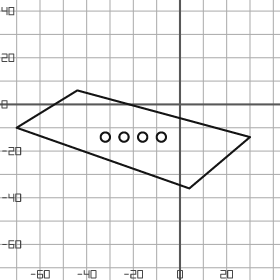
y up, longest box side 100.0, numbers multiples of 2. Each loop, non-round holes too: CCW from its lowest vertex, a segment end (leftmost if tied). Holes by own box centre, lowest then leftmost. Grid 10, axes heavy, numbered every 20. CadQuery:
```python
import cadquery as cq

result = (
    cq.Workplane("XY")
    .moveTo(4.0, -36.0)
    .lineTo(30.0, -14.0)
    .lineTo(-44.0, 6.0)
    .lineTo(-70.0, -10.0)
    .close()
    .moveTo(-32.0, -14.0)
    .circle(2.0)
    .moveTo(-24.0, -14.0)
    .circle(2.0)
    .moveTo(-16.0, -14.0)
    .circle(2.0)
    .moveTo(-8.0, -14.0)
    .circle(2.0)
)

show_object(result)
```